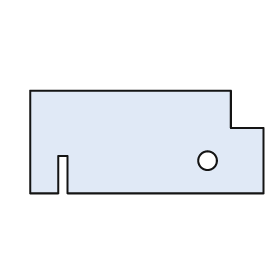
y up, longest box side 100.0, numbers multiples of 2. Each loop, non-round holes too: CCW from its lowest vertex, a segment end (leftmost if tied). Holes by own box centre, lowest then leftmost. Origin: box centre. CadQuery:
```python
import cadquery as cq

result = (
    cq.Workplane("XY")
    .moveTo(-50.0, -22.0)
    .lineTo(-38.0, -22.0)
    .lineTo(-38.0, -6.0)
    .lineTo(-34.0, -6.0)
    .lineTo(-34.0, -22.0)
    .lineTo(50.0, -22.0)
    .lineTo(50.0, 6.0)
    .lineTo(36.0, 6.0)
    .lineTo(36.0, 22.0)
    .lineTo(-50.0, 22.0)
    .close()
    .moveTo(26.0, -8.0)
    .circle(4.0)
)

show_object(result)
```